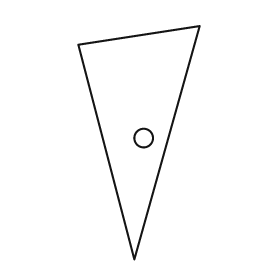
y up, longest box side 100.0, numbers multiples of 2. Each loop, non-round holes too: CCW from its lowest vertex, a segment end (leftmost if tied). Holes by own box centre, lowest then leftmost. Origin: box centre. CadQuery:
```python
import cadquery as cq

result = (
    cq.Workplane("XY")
    .moveTo(-2.0, -50.0)
    .lineTo(26.0, 50.0)
    .lineTo(-26.0, 42.0)
    .close()
    .moveTo(2.0, 2.0)
    .circle(4.0)
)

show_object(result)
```